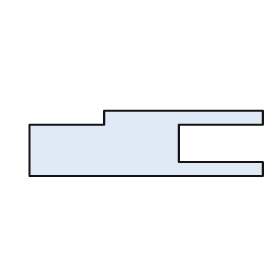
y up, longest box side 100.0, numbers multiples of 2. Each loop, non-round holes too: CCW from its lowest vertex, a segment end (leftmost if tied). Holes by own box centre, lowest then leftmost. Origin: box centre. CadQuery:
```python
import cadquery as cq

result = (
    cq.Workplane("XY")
    .moveTo(-50.0, -14.0)
    .lineTo(50.0, -14.0)
    .lineTo(50.0, -8.0)
    .lineTo(14.0, -8.0)
    .lineTo(14.0, 8.0)
    .lineTo(50.0, 8.0)
    .lineTo(50.0, 14.0)
    .lineTo(-18.0, 14.0)
    .lineTo(-18.0, 8.0)
    .lineTo(-50.0, 8.0)
    .close()
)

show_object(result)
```